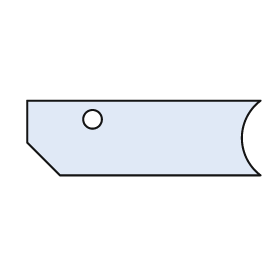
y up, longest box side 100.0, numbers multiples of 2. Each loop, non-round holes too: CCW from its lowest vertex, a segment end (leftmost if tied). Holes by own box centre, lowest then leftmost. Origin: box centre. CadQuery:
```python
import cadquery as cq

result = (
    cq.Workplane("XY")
    .moveTo(-36.0, -16.0)
    .lineTo(50.0, -16.0)
    .threePointArc((42.0, 0.0), (50.0, 16.0))
    .lineTo(-50.0, 16.0)
    .lineTo(-50.0, -2.0)
    .close()
    .moveTo(-22.0, 8.0)
    .circle(4.0)
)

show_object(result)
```